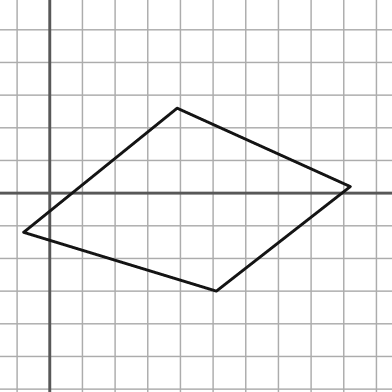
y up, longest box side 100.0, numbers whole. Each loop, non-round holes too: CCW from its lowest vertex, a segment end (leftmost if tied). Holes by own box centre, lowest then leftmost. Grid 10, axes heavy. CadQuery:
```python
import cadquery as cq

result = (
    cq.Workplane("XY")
    .moveTo(51.0, -30.0)
    .lineTo(92.0, 2.0)
    .lineTo(39.0, 26.0)
    .lineTo(-8.0, -12.0)
    .close()
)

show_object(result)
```